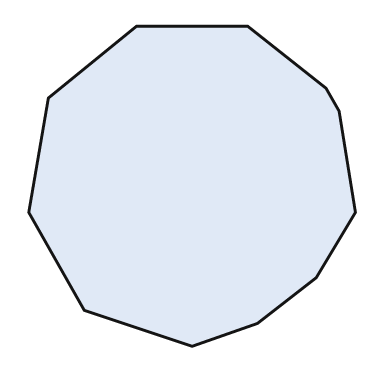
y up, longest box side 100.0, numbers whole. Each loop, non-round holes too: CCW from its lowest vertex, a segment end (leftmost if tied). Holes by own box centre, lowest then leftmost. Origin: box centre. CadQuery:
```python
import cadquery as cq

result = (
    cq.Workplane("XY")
    .moveTo(0.0, -49.0)
    .lineTo(20.0, -42.0)
    .lineTo(38.0, -28.0)
    .lineTo(50.0, -8.0)
    .lineTo(45.0, 23.0)
    .lineTo(41.0, 30.0)
    .lineTo(17.0, 49.0)
    .lineTo(-17.0, 49.0)
    .lineTo(-44.0, 27.0)
    .lineTo(-50.0, -8.0)
    .lineTo(-33.0, -38.0)
    .close()
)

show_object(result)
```